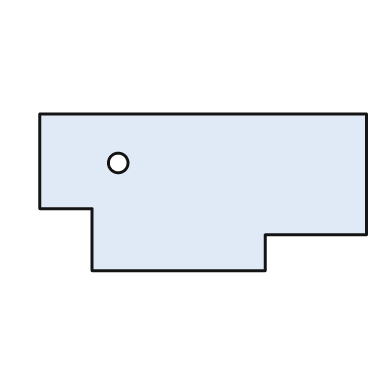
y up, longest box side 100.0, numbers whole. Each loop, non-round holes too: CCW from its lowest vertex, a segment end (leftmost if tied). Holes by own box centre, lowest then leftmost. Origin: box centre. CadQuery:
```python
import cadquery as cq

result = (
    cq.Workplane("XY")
    .moveTo(-34.0, -24.0)
    .lineTo(19.0, -24.0)
    .lineTo(19.0, -13.0)
    .lineTo(50.0, -13.0)
    .lineTo(50.0, 24.0)
    .lineTo(-50.0, 24.0)
    .lineTo(-50.0, -5.0)
    .lineTo(-34.0, -5.0)
    .close()
    .moveTo(-26.0, 9.0)
    .circle(3.0)
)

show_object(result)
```